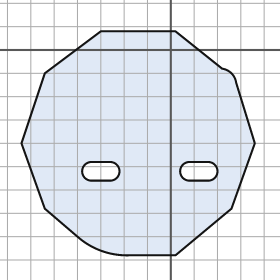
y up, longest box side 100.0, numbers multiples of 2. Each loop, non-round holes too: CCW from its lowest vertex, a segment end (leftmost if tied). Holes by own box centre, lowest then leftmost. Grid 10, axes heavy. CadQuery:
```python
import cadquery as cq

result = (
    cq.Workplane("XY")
    .moveTo(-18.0, -88.0)
    .lineTo(2.0, -88.0)
    .lineTo(26.0, -68.0)
    .lineTo(36.0, -40.0)
    .lineTo(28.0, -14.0)
    .threePointArc((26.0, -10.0), (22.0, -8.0))
    .lineTo(2.0, 8.0)
    .lineTo(-30.0, 8.0)
    .lineTo(-54.0, -10.0)
    .lineTo(-64.0, -40.0)
    .lineTo(-54.0, -68.0)
    .lineTo(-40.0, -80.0)
    .threePointArc((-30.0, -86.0), (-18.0, -88.0))
    .close()
    .moveTo(-34.0, -56.0)
    .lineTo(-26.0, -56.0)
    .threePointArc((-22.0, -52.0), (-26.0, -48.0))
    .lineTo(-34.0, -48.0)
    .threePointArc((-38.0, -52.0), (-34.0, -56.0))
    .close()
    .moveTo(8.0, -56.0)
    .lineTo(16.0, -56.0)
    .threePointArc((20.0, -52.0), (16.0, -48.0))
    .lineTo(8.0, -48.0)
    .threePointArc((4.0, -52.0), (8.0, -56.0))
    .close()
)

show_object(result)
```